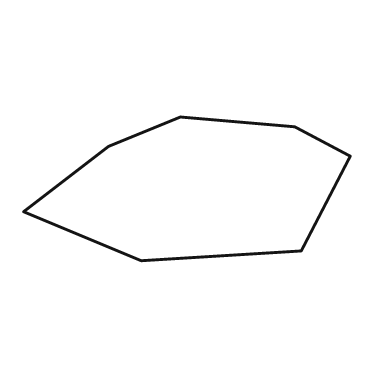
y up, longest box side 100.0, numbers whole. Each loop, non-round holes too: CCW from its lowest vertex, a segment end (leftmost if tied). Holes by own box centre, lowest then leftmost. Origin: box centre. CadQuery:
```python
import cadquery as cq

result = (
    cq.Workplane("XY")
    .moveTo(-14.0, -22.0)
    .lineTo(35.0, -19.0)
    .lineTo(50.0, 10.0)
    .lineTo(33.0, 19.0)
    .lineTo(-2.0, 22.0)
    .lineTo(-24.0, 13.0)
    .lineTo(-50.0, -7.0)
    .close()
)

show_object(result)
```